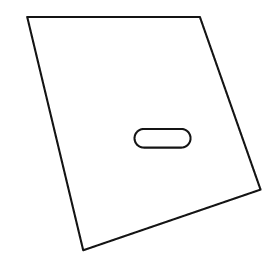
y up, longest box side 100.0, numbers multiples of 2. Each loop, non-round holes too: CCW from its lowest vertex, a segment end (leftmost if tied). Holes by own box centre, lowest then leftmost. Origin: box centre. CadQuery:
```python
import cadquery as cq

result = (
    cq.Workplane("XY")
    .moveTo(-26.0, -50.0)
    .lineTo(50.0, -24.0)
    .lineTo(24.0, 50.0)
    .lineTo(-50.0, 50.0)
    .close()
    .moveTo(0.0, -6.0)
    .lineTo(16.0, -6.0)
    .threePointArc((20.0, -2.0), (16.0, 2.0))
    .lineTo(0.0, 2.0)
    .threePointArc((-4.0, -2.0), (0.0, -6.0))
    .close()
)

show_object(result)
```